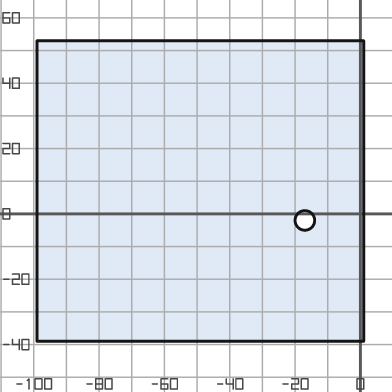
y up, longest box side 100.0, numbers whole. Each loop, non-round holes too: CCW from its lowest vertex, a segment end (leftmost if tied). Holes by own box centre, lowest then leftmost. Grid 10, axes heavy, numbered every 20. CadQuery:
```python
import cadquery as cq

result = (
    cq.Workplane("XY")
    .moveTo(-99.0, -39.0)
    .lineTo(1.0, -39.0)
    .lineTo(1.0, 53.0)
    .lineTo(-99.0, 53.0)
    .close()
    .moveTo(-17.0, -2.0)
    .circle(3.0)
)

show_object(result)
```